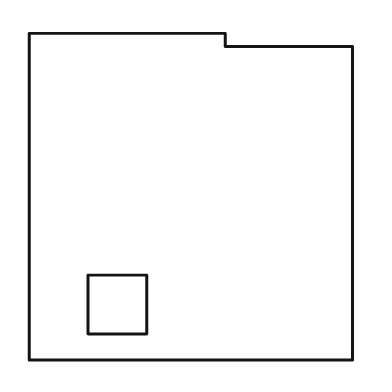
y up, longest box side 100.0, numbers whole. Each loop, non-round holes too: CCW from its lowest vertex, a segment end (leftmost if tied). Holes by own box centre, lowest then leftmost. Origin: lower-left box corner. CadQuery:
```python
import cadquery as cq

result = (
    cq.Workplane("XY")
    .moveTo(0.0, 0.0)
    .lineTo(99.0, 0.0)
    .lineTo(99.0, 96.0)
    .lineTo(60.0, 96.0)
    .lineTo(60.0, 100.0)
    .lineTo(0.0, 100.0)
    .close()
    .moveTo(18.0, 8.0)
    .lineTo(36.0, 8.0)
    .lineTo(36.0, 26.0)
    .lineTo(18.0, 26.0)
    .close()
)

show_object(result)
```